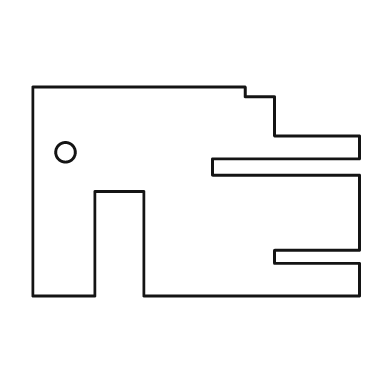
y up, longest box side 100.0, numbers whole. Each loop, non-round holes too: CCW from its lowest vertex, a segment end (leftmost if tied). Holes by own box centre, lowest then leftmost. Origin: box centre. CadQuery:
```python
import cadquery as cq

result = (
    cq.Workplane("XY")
    .moveTo(-50.0, -32.0)
    .lineTo(-31.0, -32.0)
    .lineTo(-31.0, 0.0)
    .lineTo(-16.0, 0.0)
    .lineTo(-16.0, -32.0)
    .lineTo(50.0, -32.0)
    .lineTo(50.0, -22.0)
    .lineTo(24.0, -22.0)
    .lineTo(24.0, -18.0)
    .lineTo(50.0, -18.0)
    .lineTo(50.0, 5.0)
    .lineTo(5.0, 5.0)
    .lineTo(5.0, 10.0)
    .lineTo(50.0, 10.0)
    .lineTo(50.0, 17.0)
    .lineTo(24.0, 17.0)
    .lineTo(24.0, 29.0)
    .lineTo(15.0, 29.0)
    .lineTo(15.0, 32.0)
    .lineTo(-50.0, 32.0)
    .close()
    .moveTo(-40.0, 12.0)
    .circle(3.0)
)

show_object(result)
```